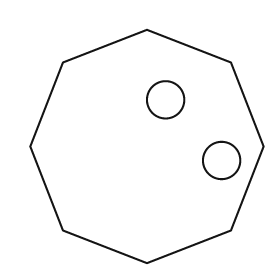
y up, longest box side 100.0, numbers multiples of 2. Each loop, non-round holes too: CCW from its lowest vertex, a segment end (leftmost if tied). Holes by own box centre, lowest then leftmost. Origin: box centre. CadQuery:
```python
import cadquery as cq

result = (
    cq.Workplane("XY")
    .moveTo(0.0, -50.0)
    .lineTo(36.0, -36.0)
    .lineTo(50.0, 0.0)
    .lineTo(36.0, 36.0)
    .lineTo(0.0, 50.0)
    .lineTo(-36.0, 36.0)
    .lineTo(-50.0, 0.0)
    .lineTo(-36.0, -36.0)
    .close()
    .moveTo(32.0, -6.0)
    .circle(8.0)
    .moveTo(8.0, 20.0)
    .circle(8.0)
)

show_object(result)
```